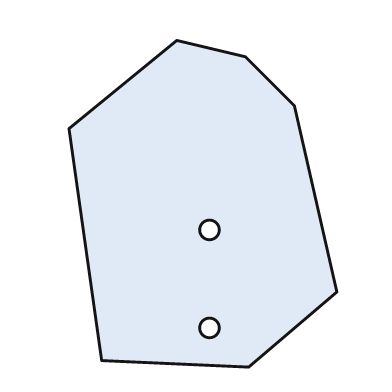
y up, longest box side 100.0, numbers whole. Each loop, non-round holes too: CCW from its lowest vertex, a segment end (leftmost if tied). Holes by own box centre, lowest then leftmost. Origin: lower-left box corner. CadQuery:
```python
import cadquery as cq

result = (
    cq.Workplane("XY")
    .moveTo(55.0, 0.0)
    .lineTo(82.0, 23.0)
    .lineTo(69.0, 80.0)
    .lineTo(54.0, 95.0)
    .lineTo(33.0, 100.0)
    .lineTo(0.0, 73.0)
    .lineTo(10.0, 2.0)
    .close()
    .moveTo(43.0, 12.0)
    .circle(3.0)
    .moveTo(43.0, 42.0)
    .circle(3.0)
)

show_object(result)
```